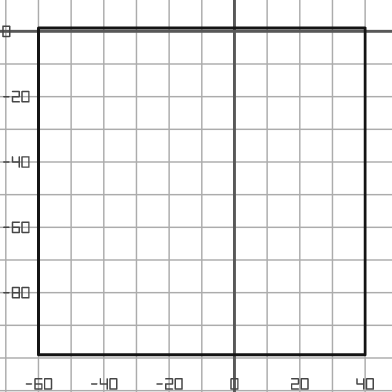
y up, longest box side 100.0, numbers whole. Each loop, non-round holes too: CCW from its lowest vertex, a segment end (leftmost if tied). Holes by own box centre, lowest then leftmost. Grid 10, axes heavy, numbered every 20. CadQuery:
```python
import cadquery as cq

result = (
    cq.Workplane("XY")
    .moveTo(-60.0, -99.0)
    .lineTo(40.0, -99.0)
    .lineTo(40.0, 1.0)
    .lineTo(-60.0, 1.0)
    .close()
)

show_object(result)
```